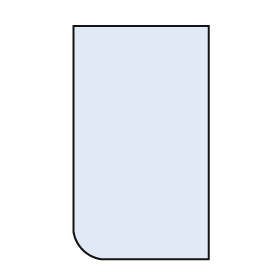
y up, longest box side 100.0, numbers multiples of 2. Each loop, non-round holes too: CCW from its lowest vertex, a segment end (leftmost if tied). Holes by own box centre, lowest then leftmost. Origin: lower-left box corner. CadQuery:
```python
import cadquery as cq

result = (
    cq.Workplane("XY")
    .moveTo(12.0, 0.0)
    .lineTo(58.0, 0.0)
    .lineTo(58.0, 100.0)
    .lineTo(0.0, 100.0)
    .lineTo(0.0, 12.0)
    .threePointArc((4.0, 4.0), (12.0, 0.0))
    .close()
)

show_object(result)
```